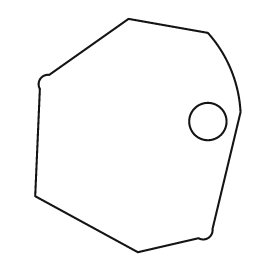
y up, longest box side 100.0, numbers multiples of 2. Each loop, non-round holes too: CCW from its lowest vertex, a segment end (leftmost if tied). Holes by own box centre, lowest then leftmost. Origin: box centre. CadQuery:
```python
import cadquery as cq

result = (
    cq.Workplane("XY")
    .moveTo(0.0, -50.0)
    .lineTo(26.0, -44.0)
    .threePointArc((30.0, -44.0), (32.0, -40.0))
    .lineTo(44.0, 10.0)
    .threePointArc((40.0, 28.0), (30.0, 44.0))
    .lineTo(-4.0, 50.0)
    .lineTo(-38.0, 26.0)
    .threePointArc((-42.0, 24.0), (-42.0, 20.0))
    .lineTo(-44.0, -26.0)
    .close()
    .moveTo(30.0, 6.0)
    .circle(8.0)
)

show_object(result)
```